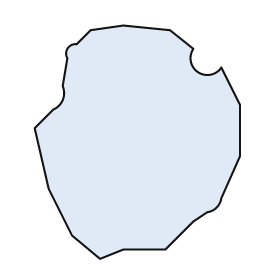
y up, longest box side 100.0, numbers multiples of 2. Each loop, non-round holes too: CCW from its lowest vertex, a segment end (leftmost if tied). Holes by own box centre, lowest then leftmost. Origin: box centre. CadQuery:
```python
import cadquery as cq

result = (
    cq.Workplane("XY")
    .moveTo(-16.0, -50.0)
    .lineTo(-6.0, -46.0)
    .lineTo(12.0, -46.0)
    .lineTo(24.0, -34.0)
    .lineTo(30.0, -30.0)
    .threePointArc((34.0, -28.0), (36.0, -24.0))
    .lineTo(44.0, -6.0)
    .lineTo(44.0, 16.0)
    .lineTo(36.0, 32.0)
    .threePointArc((26.0, 30.0), (24.0, 40.0))
    .lineTo(14.0, 48.0)
    .lineTo(-6.0, 50.0)
    .lineTo(-20.0, 48.0)
    .lineTo(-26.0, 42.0)
    .threePointArc((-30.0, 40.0), (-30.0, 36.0))
    .lineTo(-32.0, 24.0)
    .threePointArc((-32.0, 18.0), (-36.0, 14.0))
    .lineTo(-44.0, 6.0)
    .lineTo(-38.0, -20.0)
    .lineTo(-28.0, -40.0)
    .close()
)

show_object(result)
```